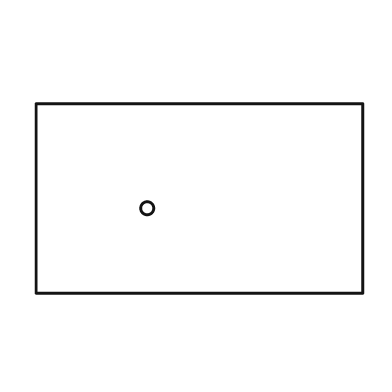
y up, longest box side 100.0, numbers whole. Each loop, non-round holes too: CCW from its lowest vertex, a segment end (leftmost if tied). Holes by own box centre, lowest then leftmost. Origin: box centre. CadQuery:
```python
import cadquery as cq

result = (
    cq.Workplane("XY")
    .moveTo(-50.0, -29.0)
    .lineTo(50.0, -29.0)
    .lineTo(50.0, 29.0)
    .lineTo(-50.0, 29.0)
    .close()
    .moveTo(-16.0, -3.0)
    .circle(2.0)
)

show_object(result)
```